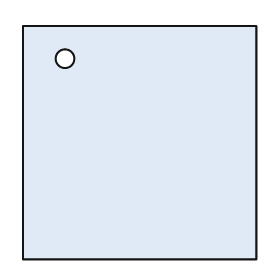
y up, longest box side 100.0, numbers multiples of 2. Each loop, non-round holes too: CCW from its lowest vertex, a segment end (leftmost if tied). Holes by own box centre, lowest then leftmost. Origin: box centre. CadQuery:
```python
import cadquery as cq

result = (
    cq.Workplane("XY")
    .moveTo(-50.0, -50.0)
    .lineTo(50.0, -50.0)
    .lineTo(50.0, 50.0)
    .lineTo(-50.0, 50.0)
    .close()
    .moveTo(-32.0, 36.0)
    .circle(4.0)
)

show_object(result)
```